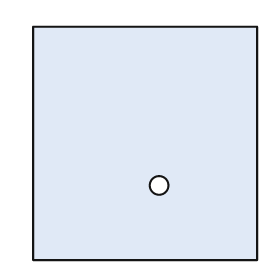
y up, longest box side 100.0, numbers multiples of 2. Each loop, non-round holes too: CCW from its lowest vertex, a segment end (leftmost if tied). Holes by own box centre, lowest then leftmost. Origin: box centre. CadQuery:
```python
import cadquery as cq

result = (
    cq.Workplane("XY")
    .moveTo(-48.0, -50.0)
    .lineTo(48.0, -50.0)
    .lineTo(48.0, 50.0)
    .lineTo(-48.0, 50.0)
    .close()
    .moveTo(6.0, -18.0)
    .circle(4.0)
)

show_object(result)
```